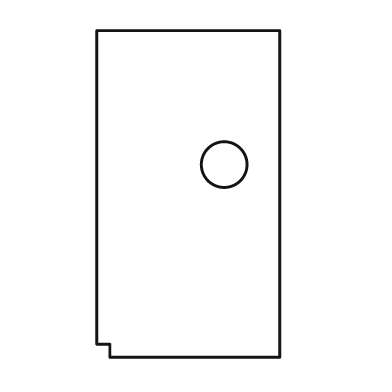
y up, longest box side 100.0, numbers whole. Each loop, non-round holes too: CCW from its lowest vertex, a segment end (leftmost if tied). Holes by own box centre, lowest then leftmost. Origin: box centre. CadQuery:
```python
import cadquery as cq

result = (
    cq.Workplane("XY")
    .moveTo(-24.0, -50.0)
    .lineTo(28.0, -50.0)
    .lineTo(28.0, 50.0)
    .lineTo(-28.0, 50.0)
    .lineTo(-28.0, -46.0)
    .lineTo(-24.0, -46.0)
    .close()
    .moveTo(11.0, 9.0)
    .circle(7.0)
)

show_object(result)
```